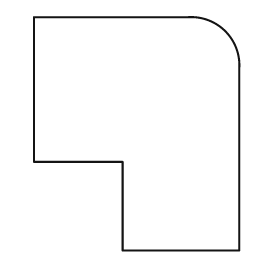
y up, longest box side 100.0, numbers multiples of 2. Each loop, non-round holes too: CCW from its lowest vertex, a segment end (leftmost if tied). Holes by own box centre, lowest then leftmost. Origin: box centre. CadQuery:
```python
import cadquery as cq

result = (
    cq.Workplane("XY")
    .moveTo(-6.0, -50.0)
    .lineTo(44.0, -50.0)
    .lineTo(44.0, 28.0)
    .threePointArc((38.0, 44.0), (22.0, 50.0))
    .lineTo(-44.0, 50.0)
    .lineTo(-44.0, -12.0)
    .lineTo(-6.0, -12.0)
    .close()
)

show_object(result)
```